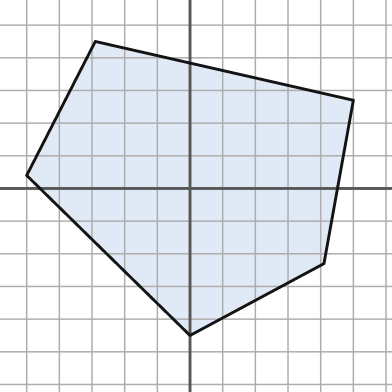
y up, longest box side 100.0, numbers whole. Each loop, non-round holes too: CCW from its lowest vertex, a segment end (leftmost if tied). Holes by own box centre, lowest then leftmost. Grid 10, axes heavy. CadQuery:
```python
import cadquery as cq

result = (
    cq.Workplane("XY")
    .moveTo(0.0, -45.0)
    .lineTo(41.0, -23.0)
    .lineTo(50.0, 27.0)
    .lineTo(-29.0, 45.0)
    .lineTo(-50.0, 4.0)
    .close()
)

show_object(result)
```